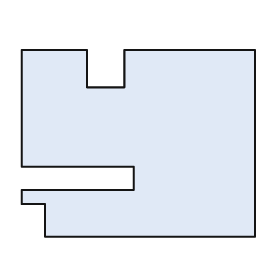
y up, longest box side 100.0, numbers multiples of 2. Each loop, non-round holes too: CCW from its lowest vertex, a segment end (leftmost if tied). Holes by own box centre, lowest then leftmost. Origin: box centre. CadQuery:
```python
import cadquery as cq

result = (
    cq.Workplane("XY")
    .moveTo(-40.0, -40.0)
    .lineTo(50.0, -40.0)
    .lineTo(50.0, 40.0)
    .lineTo(-6.0, 40.0)
    .lineTo(-6.0, 24.0)
    .lineTo(-22.0, 24.0)
    .lineTo(-22.0, 40.0)
    .lineTo(-50.0, 40.0)
    .lineTo(-50.0, -10.0)
    .lineTo(-2.0, -10.0)
    .lineTo(-2.0, -20.0)
    .lineTo(-50.0, -20.0)
    .lineTo(-50.0, -26.0)
    .lineTo(-40.0, -26.0)
    .close()
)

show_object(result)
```